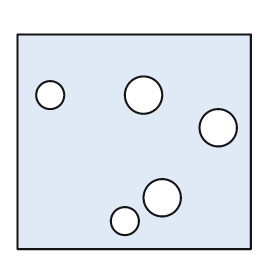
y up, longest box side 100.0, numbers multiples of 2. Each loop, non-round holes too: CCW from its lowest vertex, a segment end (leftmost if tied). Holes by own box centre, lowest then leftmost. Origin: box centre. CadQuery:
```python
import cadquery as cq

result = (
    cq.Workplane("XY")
    .moveTo(-50.0, -46.0)
    .lineTo(50.0, -46.0)
    .lineTo(50.0, 46.0)
    .lineTo(-50.0, 46.0)
    .close()
    .moveTo(-4.0, -34.0)
    .circle(6.0)
    .moveTo(12.0, -24.0)
    .circle(8.0)
    .moveTo(36.0, 6.0)
    .circle(8.0)
    .moveTo(-36.0, 20.0)
    .circle(6.0)
    .moveTo(4.0, 20.0)
    .circle(8.0)
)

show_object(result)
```